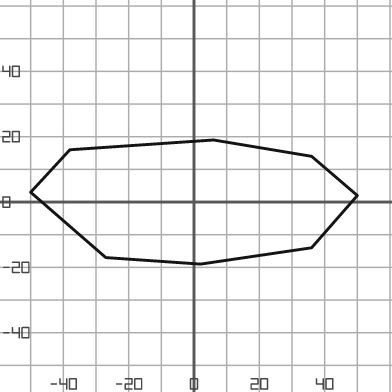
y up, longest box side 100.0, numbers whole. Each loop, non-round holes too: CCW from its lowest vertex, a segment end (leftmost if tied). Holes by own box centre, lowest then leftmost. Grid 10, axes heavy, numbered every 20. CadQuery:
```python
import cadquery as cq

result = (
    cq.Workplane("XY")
    .moveTo(2.0, -19.0)
    .lineTo(36.0, -14.0)
    .lineTo(50.0, 2.0)
    .lineTo(36.0, 14.0)
    .lineTo(6.0, 19.0)
    .lineTo(-38.0, 16.0)
    .lineTo(-50.0, 3.0)
    .lineTo(-27.0, -17.0)
    .close()
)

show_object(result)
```